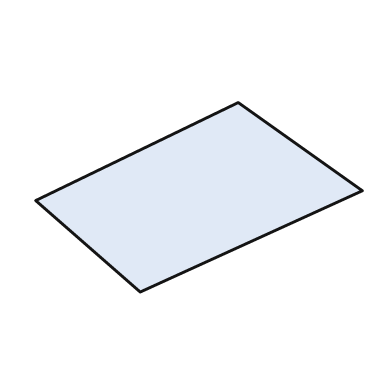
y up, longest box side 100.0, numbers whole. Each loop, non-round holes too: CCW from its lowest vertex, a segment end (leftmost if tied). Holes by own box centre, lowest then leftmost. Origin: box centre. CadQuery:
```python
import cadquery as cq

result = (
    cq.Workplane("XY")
    .moveTo(-18.0, -29.0)
    .lineTo(50.0, 2.0)
    .lineTo(12.0, 29.0)
    .lineTo(-50.0, -1.0)
    .close()
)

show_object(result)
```